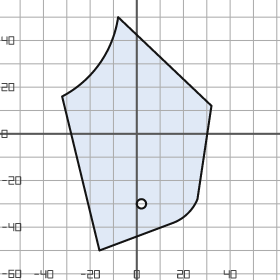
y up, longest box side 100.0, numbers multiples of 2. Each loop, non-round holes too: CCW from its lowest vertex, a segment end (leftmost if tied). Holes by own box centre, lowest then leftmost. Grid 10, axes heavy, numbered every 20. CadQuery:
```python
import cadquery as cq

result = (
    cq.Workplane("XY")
    .moveTo(-16.0, -50.0)
    .lineTo(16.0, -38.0)
    .threePointArc((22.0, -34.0), (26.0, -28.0))
    .lineTo(32.0, 12.0)
    .lineTo(-8.0, 50.0)
    .threePointArc((-16.0, 30.0), (-32.0, 16.0))
    .close()
    .moveTo(2.0, -30.0)
    .circle(2.0)
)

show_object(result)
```